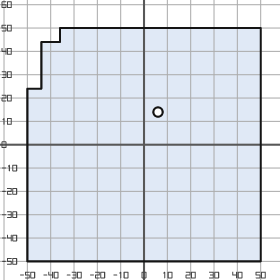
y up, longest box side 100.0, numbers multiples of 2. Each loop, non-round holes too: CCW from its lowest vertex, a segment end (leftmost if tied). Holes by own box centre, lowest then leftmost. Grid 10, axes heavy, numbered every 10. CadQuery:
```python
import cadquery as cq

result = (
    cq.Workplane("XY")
    .moveTo(-50.0, -50.0)
    .lineTo(50.0, -50.0)
    .lineTo(50.0, 50.0)
    .lineTo(-36.0, 50.0)
    .lineTo(-36.0, 44.0)
    .lineTo(-44.0, 44.0)
    .lineTo(-44.0, 24.0)
    .lineTo(-50.0, 24.0)
    .close()
    .moveTo(6.0, 14.0)
    .circle(2.0)
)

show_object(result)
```